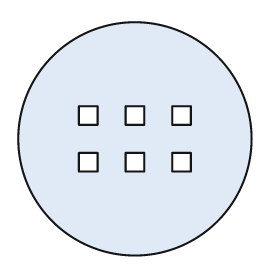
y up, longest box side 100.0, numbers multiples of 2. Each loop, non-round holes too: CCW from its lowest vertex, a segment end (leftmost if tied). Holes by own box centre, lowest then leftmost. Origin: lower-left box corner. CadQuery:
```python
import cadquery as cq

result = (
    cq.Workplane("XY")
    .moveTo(50.0, 50.0)
    .circle(50.0)
    .moveTo(26.0, 36.0)
    .lineTo(34.0, 36.0)
    .lineTo(34.0, 44.0)
    .lineTo(26.0, 44.0)
    .close()
    .moveTo(46.0, 36.0)
    .lineTo(54.0, 36.0)
    .lineTo(54.0, 44.0)
    .lineTo(46.0, 44.0)
    .close()
    .moveTo(66.0, 36.0)
    .lineTo(74.0, 36.0)
    .lineTo(74.0, 44.0)
    .lineTo(66.0, 44.0)
    .close()
    .moveTo(26.0, 56.0)
    .lineTo(34.0, 56.0)
    .lineTo(34.0, 64.0)
    .lineTo(26.0, 64.0)
    .close()
    .moveTo(46.0, 56.0)
    .lineTo(54.0, 56.0)
    .lineTo(54.0, 64.0)
    .lineTo(46.0, 64.0)
    .close()
    .moveTo(66.0, 56.0)
    .lineTo(74.0, 56.0)
    .lineTo(74.0, 64.0)
    .lineTo(66.0, 64.0)
    .close()
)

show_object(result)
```